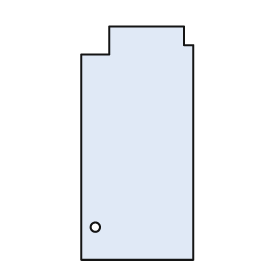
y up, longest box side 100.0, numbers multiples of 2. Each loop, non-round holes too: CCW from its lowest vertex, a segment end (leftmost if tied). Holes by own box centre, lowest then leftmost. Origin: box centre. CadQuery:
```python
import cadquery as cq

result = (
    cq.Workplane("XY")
    .moveTo(-24.0, -50.0)
    .lineTo(24.0, -50.0)
    .lineTo(24.0, 42.0)
    .lineTo(20.0, 42.0)
    .lineTo(20.0, 50.0)
    .lineTo(-12.0, 50.0)
    .lineTo(-12.0, 38.0)
    .lineTo(-24.0, 38.0)
    .close()
    .moveTo(-18.0, -36.0)
    .circle(2.0)
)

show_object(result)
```